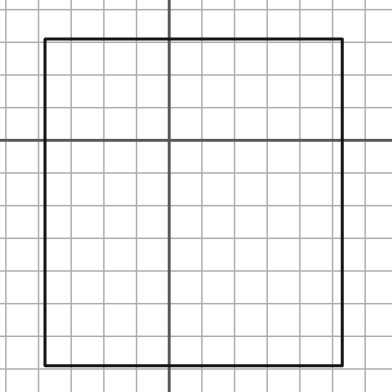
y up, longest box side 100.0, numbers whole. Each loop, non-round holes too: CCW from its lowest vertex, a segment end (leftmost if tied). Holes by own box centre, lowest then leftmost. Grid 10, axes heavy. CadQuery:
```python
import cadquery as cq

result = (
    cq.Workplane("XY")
    .moveTo(-38.0, -69.0)
    .lineTo(53.0, -69.0)
    .lineTo(53.0, 31.0)
    .lineTo(-38.0, 31.0)
    .close()
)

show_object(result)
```